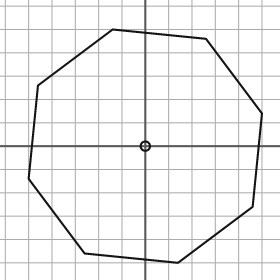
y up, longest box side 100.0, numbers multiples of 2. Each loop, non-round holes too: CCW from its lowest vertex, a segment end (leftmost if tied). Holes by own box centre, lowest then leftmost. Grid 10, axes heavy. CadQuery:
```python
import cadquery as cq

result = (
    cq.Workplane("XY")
    .moveTo(14.0, -50.0)
    .lineTo(46.0, -26.0)
    .lineTo(50.0, 14.0)
    .lineTo(26.0, 46.0)
    .lineTo(-14.0, 50.0)
    .lineTo(-46.0, 26.0)
    .lineTo(-50.0, -14.0)
    .lineTo(-26.0, -46.0)
    .close()
    .moveTo(0.0, 0.0)
    .circle(2.0)
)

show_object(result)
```